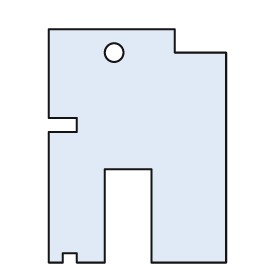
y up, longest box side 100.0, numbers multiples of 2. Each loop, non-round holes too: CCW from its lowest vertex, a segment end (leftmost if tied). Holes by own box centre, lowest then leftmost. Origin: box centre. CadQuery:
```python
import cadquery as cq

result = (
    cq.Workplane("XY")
    .moveTo(-38.0, -50.0)
    .lineTo(-32.0, -50.0)
    .lineTo(-32.0, -46.0)
    .lineTo(-26.0, -46.0)
    .lineTo(-26.0, -50.0)
    .lineTo(-14.0, -50.0)
    .lineTo(-14.0, -10.0)
    .lineTo(6.0, -10.0)
    .lineTo(6.0, -50.0)
    .lineTo(38.0, -50.0)
    .lineTo(38.0, 40.0)
    .lineTo(16.0, 40.0)
    .lineTo(16.0, 50.0)
    .lineTo(-38.0, 50.0)
    .lineTo(-38.0, 12.0)
    .lineTo(-26.0, 12.0)
    .lineTo(-26.0, 6.0)
    .lineTo(-38.0, 6.0)
    .close()
    .moveTo(-10.0, 40.0)
    .circle(4.0)
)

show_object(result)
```